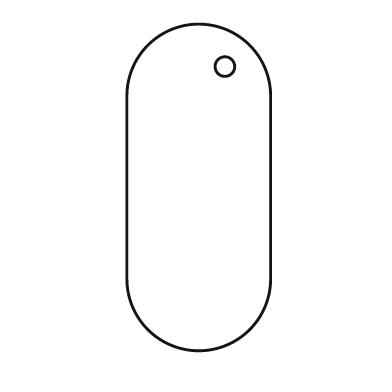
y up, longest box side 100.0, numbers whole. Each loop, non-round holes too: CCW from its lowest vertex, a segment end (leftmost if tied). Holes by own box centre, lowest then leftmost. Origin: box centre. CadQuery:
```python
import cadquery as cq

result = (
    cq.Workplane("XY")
    .moveTo(-22.0, -28.0)
    .threePointArc((0.0, -50.0), (22.0, -28.0))
    .lineTo(22.0, 28.0)
    .threePointArc((0.0, 50.0), (-22.0, 28.0))
    .close()
    .moveTo(8.0, 37.0)
    .circle(3.0)
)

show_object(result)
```